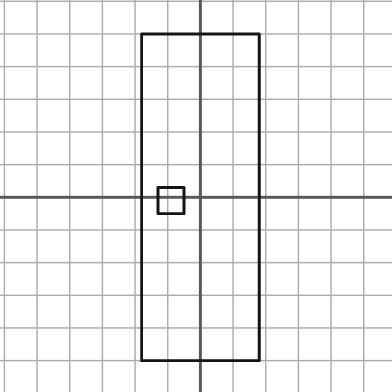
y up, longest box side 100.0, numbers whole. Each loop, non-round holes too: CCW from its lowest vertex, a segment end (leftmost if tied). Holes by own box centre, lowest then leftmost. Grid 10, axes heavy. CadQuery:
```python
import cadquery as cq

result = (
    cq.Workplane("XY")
    .moveTo(-18.0, -50.0)
    .lineTo(18.0, -50.0)
    .lineTo(18.0, 50.0)
    .lineTo(-18.0, 50.0)
    .close()
    .moveTo(-13.0, -5.0)
    .lineTo(-5.0, -5.0)
    .lineTo(-5.0, 3.0)
    .lineTo(-13.0, 3.0)
    .close()
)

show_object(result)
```